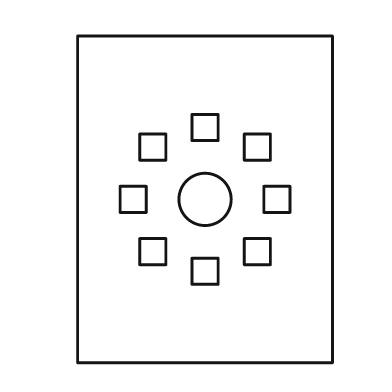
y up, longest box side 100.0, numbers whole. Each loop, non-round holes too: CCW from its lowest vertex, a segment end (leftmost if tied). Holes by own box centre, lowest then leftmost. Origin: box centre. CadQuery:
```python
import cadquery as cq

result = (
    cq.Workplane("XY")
    .moveTo(-39.0, -50.0)
    .lineTo(39.0, -50.0)
    .lineTo(39.0, 50.0)
    .lineTo(-39.0, 50.0)
    .close()
    .moveTo(-4.0, -26.0)
    .lineTo(4.0, -26.0)
    .lineTo(4.0, -18.0)
    .lineTo(-4.0, -18.0)
    .close()
    .moveTo(-20.0, -20.0)
    .lineTo(-12.0, -20.0)
    .lineTo(-12.0, -12.0)
    .lineTo(-20.0, -12.0)
    .close()
    .moveTo(12.0, -20.0)
    .lineTo(20.0, -20.0)
    .lineTo(20.0, -12.0)
    .lineTo(12.0, -12.0)
    .close()
    .moveTo(-26.0, -4.0)
    .lineTo(-18.0, -4.0)
    .lineTo(-18.0, 4.0)
    .lineTo(-26.0, 4.0)
    .close()
    .moveTo(0.0, 0.0)
    .circle(8.0)
    .moveTo(18.0, -4.0)
    .lineTo(26.0, -4.0)
    .lineTo(26.0, 4.0)
    .lineTo(18.0, 4.0)
    .close()
    .moveTo(-20.0, 12.0)
    .lineTo(-12.0, 12.0)
    .lineTo(-12.0, 20.0)
    .lineTo(-20.0, 20.0)
    .close()
    .moveTo(12.0, 12.0)
    .lineTo(20.0, 12.0)
    .lineTo(20.0, 20.0)
    .lineTo(12.0, 20.0)
    .close()
    .moveTo(-4.0, 18.0)
    .lineTo(4.0, 18.0)
    .lineTo(4.0, 26.0)
    .lineTo(-4.0, 26.0)
    .close()
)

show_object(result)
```